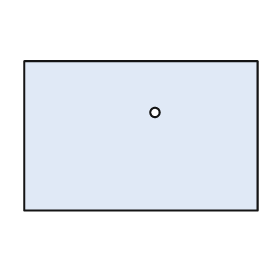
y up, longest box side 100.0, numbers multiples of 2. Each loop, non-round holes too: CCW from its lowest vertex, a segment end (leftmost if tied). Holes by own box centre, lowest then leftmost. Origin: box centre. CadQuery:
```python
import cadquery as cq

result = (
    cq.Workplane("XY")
    .moveTo(-50.0, -32.0)
    .lineTo(50.0, -32.0)
    .lineTo(50.0, 32.0)
    .lineTo(-50.0, 32.0)
    .close()
    .moveTo(6.0, 10.0)
    .circle(2.0)
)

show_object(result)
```